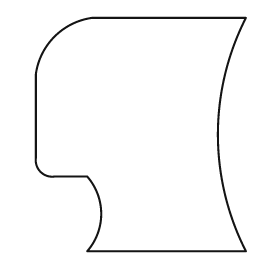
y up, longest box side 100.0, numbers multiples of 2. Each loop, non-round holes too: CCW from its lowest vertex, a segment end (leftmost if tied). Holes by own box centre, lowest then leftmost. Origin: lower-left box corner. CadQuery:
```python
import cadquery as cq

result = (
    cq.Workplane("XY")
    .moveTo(22.0, 0.0)
    .lineTo(90.0, 0.0)
    .threePointArc((78.0, 50.0), (90.0, 100.0))
    .lineTo(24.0, 100.0)
    .threePointArc((8.0, 92.0), (0.0, 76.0))
    .lineTo(0.0, 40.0)
    .threePointArc((2.0, 34.0), (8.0, 32.0))
    .lineTo(22.0, 32.0)
    .threePointArc((28.0, 16.0), (22.0, 0.0))
    .close()
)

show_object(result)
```